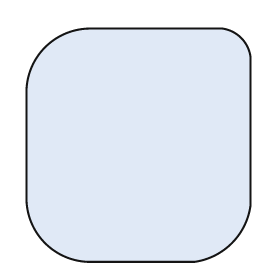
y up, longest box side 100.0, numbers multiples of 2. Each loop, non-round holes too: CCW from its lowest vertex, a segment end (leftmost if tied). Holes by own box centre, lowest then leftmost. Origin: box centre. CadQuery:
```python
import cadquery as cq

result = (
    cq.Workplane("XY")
    .moveTo(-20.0, -50.0)
    .lineTo(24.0, -50.0)
    .threePointArc((40.0, -42.0), (48.0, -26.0))
    .lineTo(48.0, 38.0)
    .threePointArc((44.0, 46.0), (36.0, 50.0))
    .lineTo(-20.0, 50.0)
    .threePointArc((-40.0, 42.0), (-48.0, 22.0))
    .lineTo(-48.0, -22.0)
    .threePointArc((-40.0, -42.0), (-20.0, -50.0))
    .close()
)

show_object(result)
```